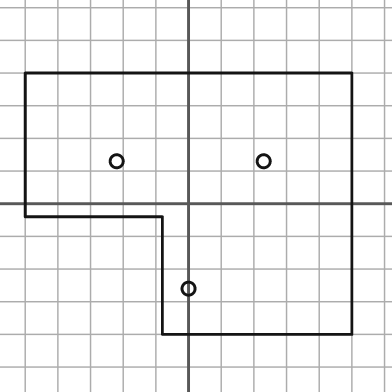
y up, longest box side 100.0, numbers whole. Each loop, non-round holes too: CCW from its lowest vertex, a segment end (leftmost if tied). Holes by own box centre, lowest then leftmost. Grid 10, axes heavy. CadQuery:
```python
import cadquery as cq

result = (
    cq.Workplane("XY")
    .moveTo(-8.0, -40.0)
    .lineTo(50.0, -40.0)
    .lineTo(50.0, 40.0)
    .lineTo(-50.0, 40.0)
    .lineTo(-50.0, -4.0)
    .lineTo(-8.0, -4.0)
    .close()
    .moveTo(0.0, -26.0)
    .circle(2.0)
    .moveTo(-22.0, 13.0)
    .circle(2.0)
    .moveTo(23.0, 13.0)
    .circle(2.0)
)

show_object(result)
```